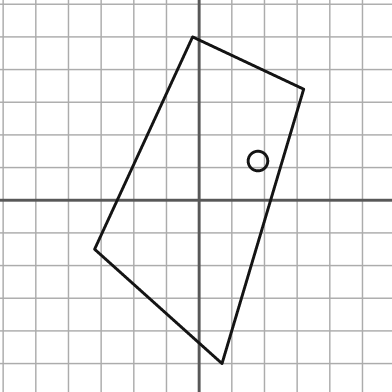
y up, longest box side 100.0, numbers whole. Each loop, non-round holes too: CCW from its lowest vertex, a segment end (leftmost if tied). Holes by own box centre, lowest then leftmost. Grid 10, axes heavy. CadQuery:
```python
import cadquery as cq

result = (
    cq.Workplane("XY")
    .moveTo(7.0, -50.0)
    .lineTo(32.0, 34.0)
    .lineTo(-2.0, 50.0)
    .lineTo(-32.0, -15.0)
    .close()
    .moveTo(18.0, 12.0)
    .circle(3.0)
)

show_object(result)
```